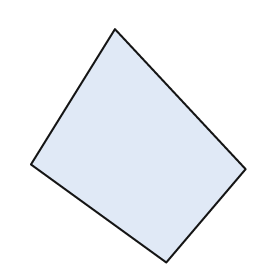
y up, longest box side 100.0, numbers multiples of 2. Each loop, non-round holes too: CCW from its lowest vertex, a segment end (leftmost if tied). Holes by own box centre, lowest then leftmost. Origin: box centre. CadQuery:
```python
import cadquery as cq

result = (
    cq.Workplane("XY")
    .moveTo(12.0, -50.0)
    .lineTo(46.0, -10.0)
    .lineTo(-10.0, 50.0)
    .lineTo(-46.0, -8.0)
    .close()
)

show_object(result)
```